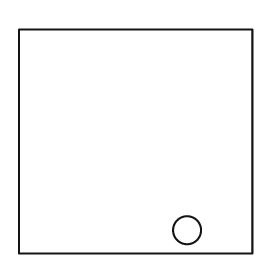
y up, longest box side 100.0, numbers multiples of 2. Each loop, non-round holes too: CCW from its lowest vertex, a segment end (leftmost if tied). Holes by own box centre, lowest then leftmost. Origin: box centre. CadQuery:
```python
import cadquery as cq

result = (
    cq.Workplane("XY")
    .moveTo(-50.0, -48.0)
    .lineTo(50.0, -48.0)
    .lineTo(50.0, 48.0)
    .lineTo(-50.0, 48.0)
    .close()
    .moveTo(22.0, -38.0)
    .circle(6.0)
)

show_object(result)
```